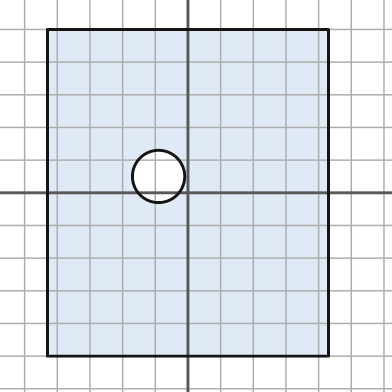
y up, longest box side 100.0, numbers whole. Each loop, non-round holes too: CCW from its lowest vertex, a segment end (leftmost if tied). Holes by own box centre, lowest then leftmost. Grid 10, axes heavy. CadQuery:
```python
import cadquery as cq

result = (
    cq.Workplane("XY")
    .moveTo(-43.0, -50.0)
    .lineTo(43.0, -50.0)
    .lineTo(43.0, 50.0)
    .lineTo(-43.0, 50.0)
    .close()
    .moveTo(-9.0, 5.0)
    .circle(8.0)
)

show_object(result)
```